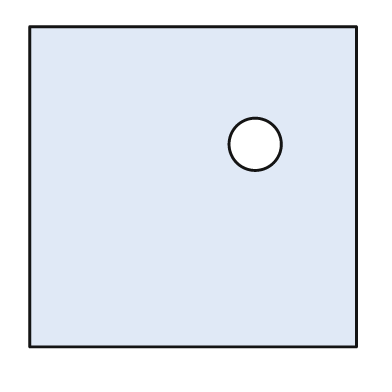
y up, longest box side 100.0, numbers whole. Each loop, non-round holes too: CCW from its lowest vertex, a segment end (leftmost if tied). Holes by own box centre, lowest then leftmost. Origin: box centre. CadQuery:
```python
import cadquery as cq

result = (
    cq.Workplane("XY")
    .moveTo(-50.0, -49.0)
    .lineTo(50.0, -49.0)
    .lineTo(50.0, 49.0)
    .lineTo(-50.0, 49.0)
    .close()
    .moveTo(19.0, 13.0)
    .circle(8.0)
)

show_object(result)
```